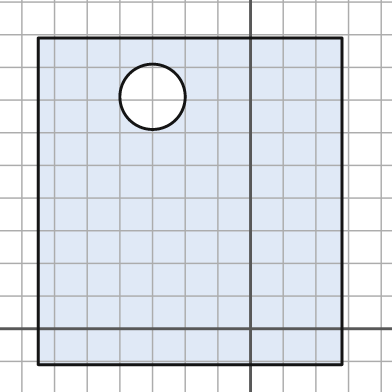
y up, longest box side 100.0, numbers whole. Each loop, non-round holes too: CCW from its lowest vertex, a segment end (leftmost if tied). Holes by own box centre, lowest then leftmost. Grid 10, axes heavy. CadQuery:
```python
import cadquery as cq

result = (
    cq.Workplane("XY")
    .moveTo(-65.0, -11.0)
    .lineTo(28.0, -11.0)
    .lineTo(28.0, 89.0)
    .lineTo(-65.0, 89.0)
    .close()
    .moveTo(-30.0, 71.0)
    .circle(10.0)
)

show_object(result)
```